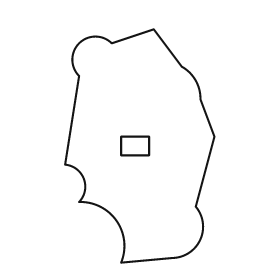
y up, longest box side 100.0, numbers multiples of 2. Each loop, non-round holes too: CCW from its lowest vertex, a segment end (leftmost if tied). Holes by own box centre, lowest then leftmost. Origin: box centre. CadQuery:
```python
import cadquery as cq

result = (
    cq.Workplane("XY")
    .moveTo(-8.0, -50.0)
    .lineTo(14.0, -48.0)
    .threePointArc((26.0, -40.0), (24.0, -26.0))
    .lineTo(32.0, 4.0)
    .lineTo(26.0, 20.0)
    .threePointArc((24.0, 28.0), (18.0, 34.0))
    .lineTo(6.0, 50.0)
    .lineTo(-12.0, 44.0)
    .threePointArc((-26.0, 44.0), (-26.0, 30.0))
    .lineTo(-32.0, -8.0)
    .threePointArc((-24.0, -14.0), (-26.0, -24.0))
    .threePointArc((-10.0, -32.0), (-8.0, -50.0))
    .close()
    .moveTo(-8.0, -4.0)
    .lineTo(4.0, -4.0)
    .lineTo(4.0, 4.0)
    .lineTo(-8.0, 4.0)
    .close()
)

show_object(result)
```